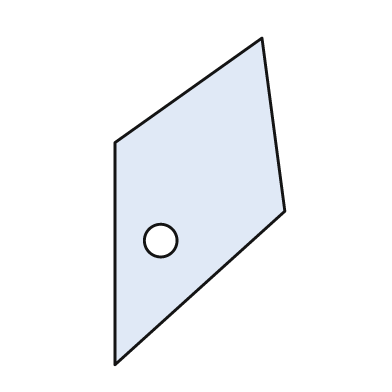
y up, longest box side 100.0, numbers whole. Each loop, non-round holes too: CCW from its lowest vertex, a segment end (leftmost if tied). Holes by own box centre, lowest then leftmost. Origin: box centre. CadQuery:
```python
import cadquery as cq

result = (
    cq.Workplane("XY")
    .moveTo(-26.0, -50.0)
    .lineTo(26.0, -3.0)
    .lineTo(19.0, 50.0)
    .lineTo(-26.0, 18.0)
    .close()
    .moveTo(-12.0, -12.0)
    .circle(5.0)
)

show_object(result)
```